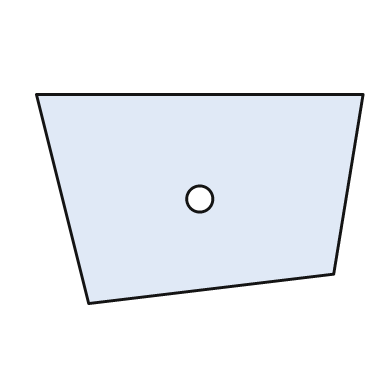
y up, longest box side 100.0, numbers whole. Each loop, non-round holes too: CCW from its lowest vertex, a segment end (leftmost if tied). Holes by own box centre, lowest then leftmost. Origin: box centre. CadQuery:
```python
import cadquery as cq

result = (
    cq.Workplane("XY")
    .moveTo(-34.0, -32.0)
    .lineTo(41.0, -23.0)
    .lineTo(50.0, 32.0)
    .lineTo(-50.0, 32.0)
    .close()
    .moveTo(0.0, 0.0)
    .circle(4.0)
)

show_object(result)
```